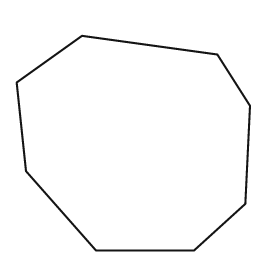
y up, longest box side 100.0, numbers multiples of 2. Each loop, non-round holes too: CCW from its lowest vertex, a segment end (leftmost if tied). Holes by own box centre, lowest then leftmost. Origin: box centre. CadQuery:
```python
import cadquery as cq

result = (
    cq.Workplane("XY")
    .moveTo(-16.0, -46.0)
    .lineTo(26.0, -46.0)
    .lineTo(48.0, -26.0)
    .lineTo(50.0, 16.0)
    .lineTo(36.0, 38.0)
    .lineTo(-22.0, 46.0)
    .lineTo(-50.0, 26.0)
    .lineTo(-46.0, -12.0)
    .close()
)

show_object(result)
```